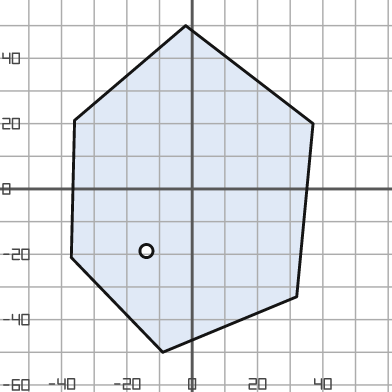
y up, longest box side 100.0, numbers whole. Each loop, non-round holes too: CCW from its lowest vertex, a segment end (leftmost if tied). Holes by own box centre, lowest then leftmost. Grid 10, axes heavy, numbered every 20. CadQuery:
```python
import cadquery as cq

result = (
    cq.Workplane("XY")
    .moveTo(-9.0, -50.0)
    .lineTo(32.0, -33.0)
    .lineTo(37.0, 20.0)
    .lineTo(-2.0, 50.0)
    .lineTo(-36.0, 21.0)
    .lineTo(-37.0, -21.0)
    .close()
    .moveTo(-14.0, -19.0)
    .circle(2.0)
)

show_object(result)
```